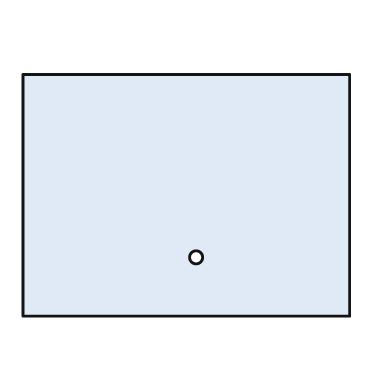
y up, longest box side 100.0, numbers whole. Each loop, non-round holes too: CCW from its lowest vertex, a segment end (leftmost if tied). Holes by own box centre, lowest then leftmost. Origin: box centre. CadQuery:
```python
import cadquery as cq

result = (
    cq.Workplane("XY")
    .moveTo(-50.0, -37.0)
    .lineTo(50.0, -37.0)
    .lineTo(50.0, 37.0)
    .lineTo(-50.0, 37.0)
    .close()
    .moveTo(3.0, -19.0)
    .circle(2.0)
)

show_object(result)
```